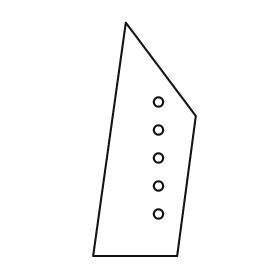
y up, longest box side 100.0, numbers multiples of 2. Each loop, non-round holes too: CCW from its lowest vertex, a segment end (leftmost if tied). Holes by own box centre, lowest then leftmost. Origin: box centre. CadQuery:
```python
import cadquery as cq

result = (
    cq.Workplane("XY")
    .moveTo(-22.0, -50.0)
    .lineTo(14.0, -50.0)
    .lineTo(22.0, 10.0)
    .lineTo(-8.0, 50.0)
    .close()
    .moveTo(6.0, -32.0)
    .circle(2.0)
    .moveTo(6.0, -20.0)
    .circle(2.0)
    .moveTo(6.0, -8.0)
    .circle(2.0)
    .moveTo(6.0, 4.0)
    .circle(2.0)
    .moveTo(6.0, 16.0)
    .circle(2.0)
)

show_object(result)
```